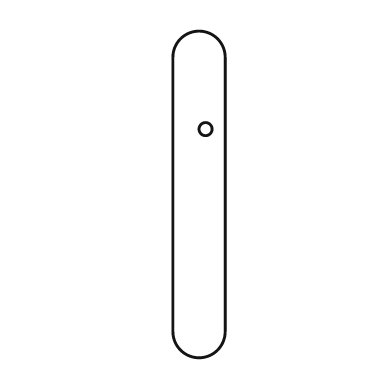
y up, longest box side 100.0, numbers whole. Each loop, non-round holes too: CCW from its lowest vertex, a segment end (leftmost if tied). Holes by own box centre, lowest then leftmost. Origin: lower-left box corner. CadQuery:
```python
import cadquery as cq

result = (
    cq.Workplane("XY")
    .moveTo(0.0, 8.0)
    .threePointArc((8.0, 0.0), (16.0, 8.0))
    .lineTo(16.0, 92.0)
    .threePointArc((8.0, 100.0), (0.0, 92.0))
    .close()
    .moveTo(10.0, 70.0)
    .circle(2.0)
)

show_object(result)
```